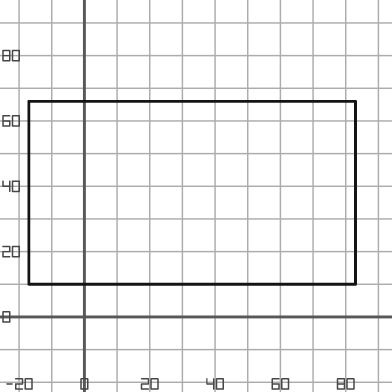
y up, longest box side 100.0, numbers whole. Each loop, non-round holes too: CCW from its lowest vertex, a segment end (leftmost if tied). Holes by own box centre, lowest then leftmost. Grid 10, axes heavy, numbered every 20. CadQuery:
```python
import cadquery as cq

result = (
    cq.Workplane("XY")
    .moveTo(-17.0, 10.0)
    .lineTo(83.0, 10.0)
    .lineTo(83.0, 66.0)
    .lineTo(-17.0, 66.0)
    .close()
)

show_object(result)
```